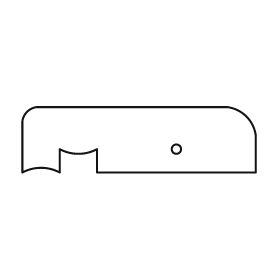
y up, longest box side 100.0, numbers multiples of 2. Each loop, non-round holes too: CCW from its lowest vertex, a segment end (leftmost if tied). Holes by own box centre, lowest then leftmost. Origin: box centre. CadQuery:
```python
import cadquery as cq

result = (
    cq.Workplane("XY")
    .moveTo(-50.0, -14.0)
    .threePointArc((-42.0, -12.0), (-34.0, -14.0))
    .lineTo(-34.0, -4.0)
    .threePointArc((-26.0, -6.0), (-18.0, -4.0))
    .lineTo(-18.0, -14.0)
    .lineTo(50.0, -14.0)
    .lineTo(50.0, 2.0)
    .threePointArc((46.0, 10.0), (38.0, 14.0))
    .lineTo(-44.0, 14.0)
    .threePointArc((-48.0, 12.0), (-50.0, 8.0))
    .close()
    .moveTo(16.0, -4.0)
    .circle(2.0)
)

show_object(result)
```